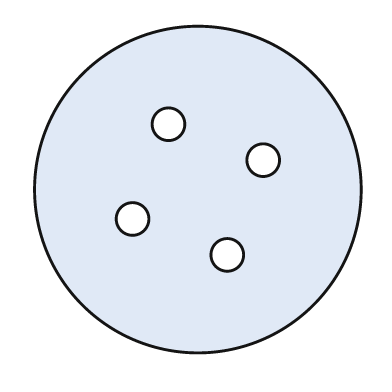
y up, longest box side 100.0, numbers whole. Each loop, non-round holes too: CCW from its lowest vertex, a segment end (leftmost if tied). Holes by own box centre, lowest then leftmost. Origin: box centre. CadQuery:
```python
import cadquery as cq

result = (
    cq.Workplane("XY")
    .moveTo(0.0, 0.0)
    .circle(50.0)
    .moveTo(9.0, -20.0)
    .circle(5.0)
    .moveTo(-20.0, -9.0)
    .circle(5.0)
    .moveTo(20.0, 9.0)
    .circle(5.0)
    .moveTo(-9.0, 20.0)
    .circle(5.0)
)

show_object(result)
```